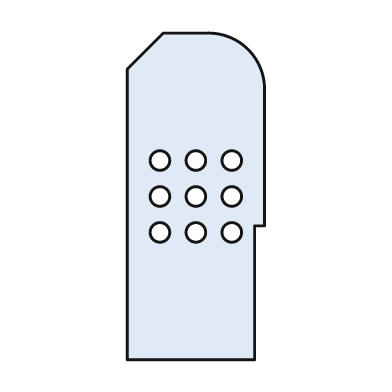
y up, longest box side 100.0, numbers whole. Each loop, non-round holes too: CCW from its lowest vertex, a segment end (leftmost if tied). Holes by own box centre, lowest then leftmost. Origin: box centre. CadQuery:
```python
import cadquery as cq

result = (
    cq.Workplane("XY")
    .moveTo(-21.0, -50.0)
    .lineTo(18.0, -50.0)
    .lineTo(18.0, -9.0)
    .lineTo(21.0, -9.0)
    .lineTo(21.0, 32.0)
    .threePointArc((16.0, 45.0), (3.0, 50.0))
    .lineTo(-10.0, 50.0)
    .lineTo(-21.0, 39.0)
    .close()
    .moveTo(-11.0, -11.0)
    .circle(3.0)
    .moveTo(0.0, -11.0)
    .circle(3.0)
    .moveTo(11.0, -11.0)
    .circle(3.0)
    .moveTo(-11.0, 0.0)
    .circle(3.0)
    .moveTo(0.0, 0.0)
    .circle(3.0)
    .moveTo(11.0, 0.0)
    .circle(3.0)
    .moveTo(-11.0, 11.0)
    .circle(3.0)
    .moveTo(0.0, 11.0)
    .circle(3.0)
    .moveTo(11.0, 11.0)
    .circle(3.0)
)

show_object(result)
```